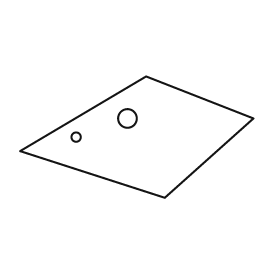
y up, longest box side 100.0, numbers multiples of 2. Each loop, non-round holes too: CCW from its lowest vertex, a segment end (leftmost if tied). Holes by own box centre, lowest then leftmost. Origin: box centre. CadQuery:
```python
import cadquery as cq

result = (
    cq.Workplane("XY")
    .moveTo(12.0, -26.0)
    .lineTo(50.0, 8.0)
    .lineTo(4.0, 26.0)
    .lineTo(-50.0, -6.0)
    .close()
    .moveTo(-26.0, 0.0)
    .circle(2.0)
    .moveTo(-4.0, 8.0)
    .circle(4.0)
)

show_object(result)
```